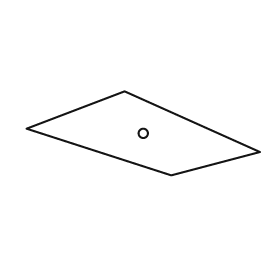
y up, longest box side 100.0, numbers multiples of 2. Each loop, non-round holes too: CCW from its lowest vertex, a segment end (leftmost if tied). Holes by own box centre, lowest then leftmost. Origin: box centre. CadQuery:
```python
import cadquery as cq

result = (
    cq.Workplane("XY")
    .moveTo(12.0, -18.0)
    .lineTo(50.0, -8.0)
    .lineTo(-8.0, 18.0)
    .lineTo(-50.0, 2.0)
    .close()
    .moveTo(0.0, 0.0)
    .circle(2.0)
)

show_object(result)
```